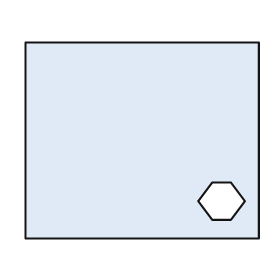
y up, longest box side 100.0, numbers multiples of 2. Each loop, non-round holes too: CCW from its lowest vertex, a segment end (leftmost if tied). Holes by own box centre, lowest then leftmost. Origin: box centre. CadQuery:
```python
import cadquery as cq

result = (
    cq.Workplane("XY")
    .moveTo(-50.0, -42.0)
    .lineTo(50.0, -42.0)
    .lineTo(50.0, 42.0)
    .lineTo(-50.0, 42.0)
    .close()
    .moveTo(30.0, -34.0)
    .lineTo(38.0, -34.0)
    .lineTo(44.0, -26.0)
    .lineTo(38.0, -18.0)
    .lineTo(30.0, -18.0)
    .lineTo(24.0, -26.0)
    .close()
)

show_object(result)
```